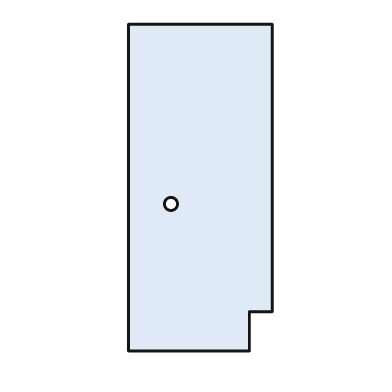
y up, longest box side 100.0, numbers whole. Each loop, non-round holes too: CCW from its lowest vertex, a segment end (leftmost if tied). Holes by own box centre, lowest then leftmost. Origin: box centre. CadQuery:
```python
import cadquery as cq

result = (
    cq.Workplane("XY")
    .moveTo(-22.0, -50.0)
    .lineTo(15.0, -50.0)
    .lineTo(15.0, -38.0)
    .lineTo(22.0, -38.0)
    .lineTo(22.0, 50.0)
    .lineTo(-22.0, 50.0)
    .close()
    .moveTo(-9.0, -5.0)
    .circle(2.0)
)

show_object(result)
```